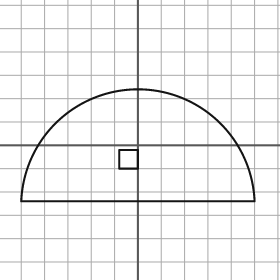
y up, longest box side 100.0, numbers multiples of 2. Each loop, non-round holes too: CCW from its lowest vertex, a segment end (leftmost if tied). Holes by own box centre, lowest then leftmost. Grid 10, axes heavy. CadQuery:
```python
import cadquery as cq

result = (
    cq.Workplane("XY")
    .moveTo(-50.0, -24.0)
    .lineTo(50.0, -24.0)
    .threePointArc((0.0, 24.0), (-50.0, -24.0))
    .close()
    .moveTo(-8.0, -10.0)
    .lineTo(0.0, -10.0)
    .lineTo(0.0, -2.0)
    .lineTo(-8.0, -2.0)
    .close()
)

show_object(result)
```